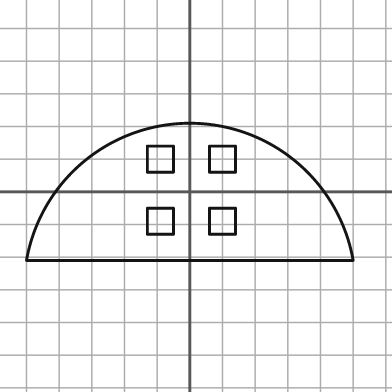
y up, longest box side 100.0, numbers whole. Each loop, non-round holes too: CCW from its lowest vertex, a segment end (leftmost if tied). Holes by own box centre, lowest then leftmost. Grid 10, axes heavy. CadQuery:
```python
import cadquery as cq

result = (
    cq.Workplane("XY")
    .moveTo(-50.0, -21.0)
    .lineTo(50.0, -21.0)
    .threePointArc((0.0, 21.0), (-50.0, -21.0))
    .close()
    .moveTo(-13.0, -13.0)
    .lineTo(-5.0, -13.0)
    .lineTo(-5.0, -5.0)
    .lineTo(-13.0, -5.0)
    .close()
    .moveTo(6.0, -13.0)
    .lineTo(14.0, -13.0)
    .lineTo(14.0, -5.0)
    .lineTo(6.0, -5.0)
    .close()
    .moveTo(-13.0, 6.0)
    .lineTo(-5.0, 6.0)
    .lineTo(-5.0, 14.0)
    .lineTo(-13.0, 14.0)
    .close()
    .moveTo(6.0, 6.0)
    .lineTo(14.0, 6.0)
    .lineTo(14.0, 14.0)
    .lineTo(6.0, 14.0)
    .close()
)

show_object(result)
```